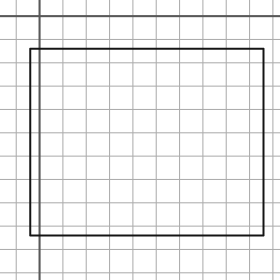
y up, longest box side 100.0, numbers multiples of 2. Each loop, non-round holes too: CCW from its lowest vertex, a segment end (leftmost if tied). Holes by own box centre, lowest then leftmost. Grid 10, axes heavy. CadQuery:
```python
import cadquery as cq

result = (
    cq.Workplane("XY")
    .moveTo(-4.0, -94.0)
    .lineTo(96.0, -94.0)
    .lineTo(96.0, -14.0)
    .lineTo(-4.0, -14.0)
    .close()
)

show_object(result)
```